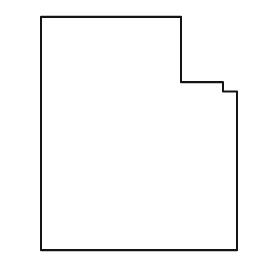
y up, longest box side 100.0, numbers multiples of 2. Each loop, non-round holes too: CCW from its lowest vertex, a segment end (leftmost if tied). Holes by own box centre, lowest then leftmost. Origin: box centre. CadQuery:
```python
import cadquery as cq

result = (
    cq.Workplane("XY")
    .moveTo(-42.0, -50.0)
    .lineTo(42.0, -50.0)
    .lineTo(42.0, 18.0)
    .lineTo(36.0, 18.0)
    .lineTo(36.0, 22.0)
    .lineTo(18.0, 22.0)
    .lineTo(18.0, 50.0)
    .lineTo(-42.0, 50.0)
    .close()
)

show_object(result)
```